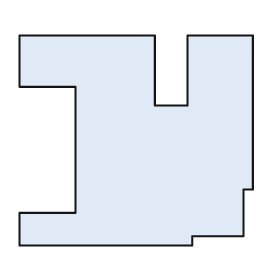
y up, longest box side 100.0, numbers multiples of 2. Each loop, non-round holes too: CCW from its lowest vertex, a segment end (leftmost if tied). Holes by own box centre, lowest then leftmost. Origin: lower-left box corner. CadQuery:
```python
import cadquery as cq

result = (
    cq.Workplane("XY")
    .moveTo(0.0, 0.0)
    .lineTo(74.0, 0.0)
    .lineTo(74.0, 4.0)
    .lineTo(96.0, 4.0)
    .lineTo(96.0, 24.0)
    .lineTo(100.0, 24.0)
    .lineTo(100.0, 90.0)
    .lineTo(72.0, 90.0)
    .lineTo(72.0, 60.0)
    .lineTo(58.0, 60.0)
    .lineTo(58.0, 90.0)
    .lineTo(0.0, 90.0)
    .lineTo(0.0, 68.0)
    .lineTo(24.0, 68.0)
    .lineTo(24.0, 14.0)
    .lineTo(0.0, 14.0)
    .close()
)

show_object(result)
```